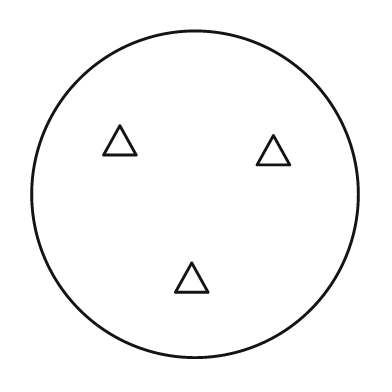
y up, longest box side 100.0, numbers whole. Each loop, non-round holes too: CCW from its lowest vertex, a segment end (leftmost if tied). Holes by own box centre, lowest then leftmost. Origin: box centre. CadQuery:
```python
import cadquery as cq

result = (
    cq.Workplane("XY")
    .moveTo(0.0, 0.0)
    .circle(50.0)
    .moveTo(-6.0, -30.0)
    .lineTo(4.0, -30.0)
    .lineTo(-1.0, -21.0)
    .close()
    .moveTo(19.0, 9.0)
    .lineTo(29.0, 9.0)
    .lineTo(24.0, 18.0)
    .close()
    .moveTo(-28.0, 12.0)
    .lineTo(-18.0, 12.0)
    .lineTo(-23.0, 21.0)
    .close()
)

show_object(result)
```